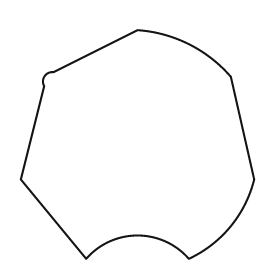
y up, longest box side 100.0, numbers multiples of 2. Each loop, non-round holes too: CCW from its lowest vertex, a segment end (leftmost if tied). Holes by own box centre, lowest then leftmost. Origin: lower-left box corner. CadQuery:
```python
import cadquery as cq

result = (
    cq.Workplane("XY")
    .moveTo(28.0, 0.0)
    .threePointArc((50.0, 10.0), (72.0, 0.0))
    .threePointArc((90.0, 14.0), (100.0, 34.0))
    .lineTo(90.0, 78.0)
    .threePointArc((72.0, 92.0), (50.0, 98.0))
    .lineTo(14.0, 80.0)
    .threePointArc((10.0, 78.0), (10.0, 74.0))
    .lineTo(0.0, 34.0)
    .close()
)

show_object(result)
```